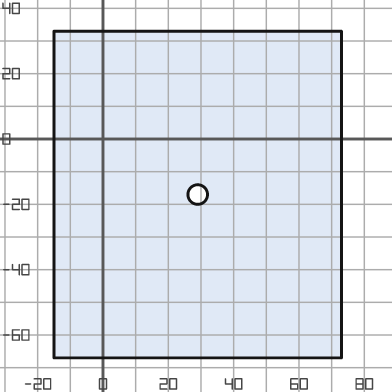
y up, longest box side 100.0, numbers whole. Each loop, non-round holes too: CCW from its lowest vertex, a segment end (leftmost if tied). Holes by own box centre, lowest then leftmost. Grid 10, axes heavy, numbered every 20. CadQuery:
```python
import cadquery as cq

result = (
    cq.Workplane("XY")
    .moveTo(-15.0, -67.0)
    .lineTo(73.0, -67.0)
    .lineTo(73.0, 33.0)
    .lineTo(-15.0, 33.0)
    .close()
    .moveTo(29.0, -17.0)
    .circle(3.0)
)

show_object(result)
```